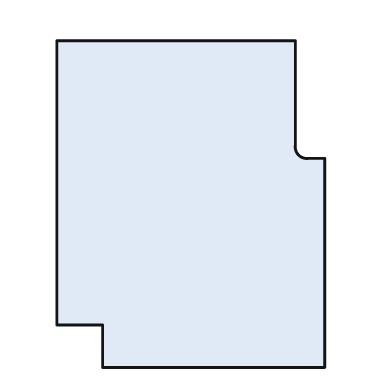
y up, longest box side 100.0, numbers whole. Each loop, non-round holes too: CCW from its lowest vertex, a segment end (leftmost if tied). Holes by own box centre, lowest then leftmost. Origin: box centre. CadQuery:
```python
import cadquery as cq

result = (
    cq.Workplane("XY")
    .moveTo(-27.0, -50.0)
    .lineTo(41.0, -50.0)
    .lineTo(41.0, 14.0)
    .lineTo(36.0, 14.0)
    .threePointArc((33.0, 15.0), (32.0, 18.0))
    .lineTo(32.0, 50.0)
    .lineTo(-41.0, 50.0)
    .lineTo(-41.0, -37.0)
    .lineTo(-27.0, -37.0)
    .close()
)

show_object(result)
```